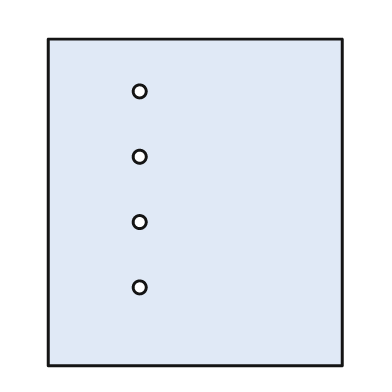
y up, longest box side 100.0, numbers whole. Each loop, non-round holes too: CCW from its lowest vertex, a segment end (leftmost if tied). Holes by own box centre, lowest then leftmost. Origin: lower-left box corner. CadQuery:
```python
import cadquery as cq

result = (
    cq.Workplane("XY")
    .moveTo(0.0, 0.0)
    .lineTo(90.0, 0.0)
    .lineTo(90.0, 100.0)
    .lineTo(0.0, 100.0)
    .close()
    .moveTo(28.0, 24.0)
    .circle(2.0)
    .moveTo(28.0, 44.0)
    .circle(2.0)
    .moveTo(28.0, 64.0)
    .circle(2.0)
    .moveTo(28.0, 84.0)
    .circle(2.0)
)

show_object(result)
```